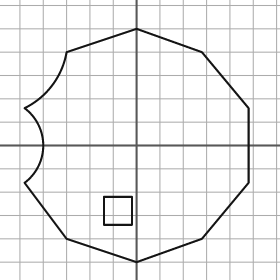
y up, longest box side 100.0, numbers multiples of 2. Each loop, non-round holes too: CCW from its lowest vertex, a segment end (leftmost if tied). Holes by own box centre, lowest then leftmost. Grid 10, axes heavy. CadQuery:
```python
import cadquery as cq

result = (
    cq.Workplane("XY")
    .moveTo(0.0, -50.0)
    .lineTo(28.0, -40.0)
    .lineTo(48.0, -16.0)
    .lineTo(48.0, 16.0)
    .lineTo(28.0, 40.0)
    .lineTo(0.0, 50.0)
    .lineTo(-30.0, 40.0)
    .threePointArc((-36.0, 26.0), (-48.0, 16.0))
    .threePointArc((-40.0, 0.0), (-48.0, -16.0))
    .lineTo(-30.0, -40.0)
    .close()
    .moveTo(-14.0, -34.0)
    .lineTo(-2.0, -34.0)
    .lineTo(-2.0, -22.0)
    .lineTo(-14.0, -22.0)
    .close()
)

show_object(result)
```